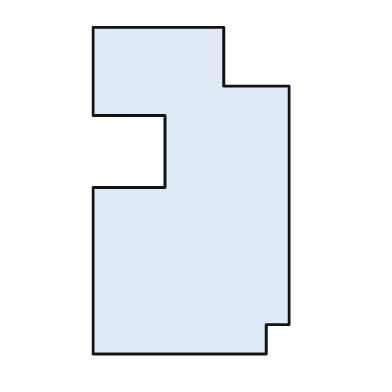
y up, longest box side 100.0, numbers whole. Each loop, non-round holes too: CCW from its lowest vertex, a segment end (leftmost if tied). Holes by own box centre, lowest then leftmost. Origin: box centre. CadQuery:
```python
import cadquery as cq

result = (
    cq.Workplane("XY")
    .moveTo(-30.0, -50.0)
    .lineTo(23.0, -50.0)
    .lineTo(23.0, -41.0)
    .lineTo(30.0, -41.0)
    .lineTo(30.0, 32.0)
    .lineTo(10.0, 32.0)
    .lineTo(10.0, 50.0)
    .lineTo(-30.0, 50.0)
    .lineTo(-30.0, 23.0)
    .lineTo(-8.0, 23.0)
    .lineTo(-8.0, 1.0)
    .lineTo(-30.0, 1.0)
    .close()
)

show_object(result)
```